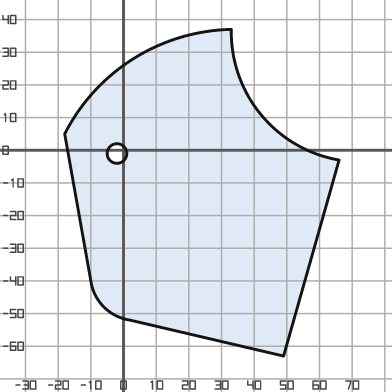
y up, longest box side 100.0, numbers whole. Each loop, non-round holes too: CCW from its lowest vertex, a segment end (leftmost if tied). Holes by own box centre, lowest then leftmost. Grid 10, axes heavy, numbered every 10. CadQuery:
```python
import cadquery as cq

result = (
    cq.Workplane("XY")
    .moveTo(49.0, -63.0)
    .lineTo(66.0, -3.0)
    .threePointArc((42.0, 11.0), (33.0, 37.0))
    .threePointArc((3.0, 28.0), (-18.0, 5.0))
    .lineTo(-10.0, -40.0)
    .threePointArc((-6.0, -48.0), (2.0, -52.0))
    .close()
    .moveTo(-2.0, -1.0)
    .circle(3.0)
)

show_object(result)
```